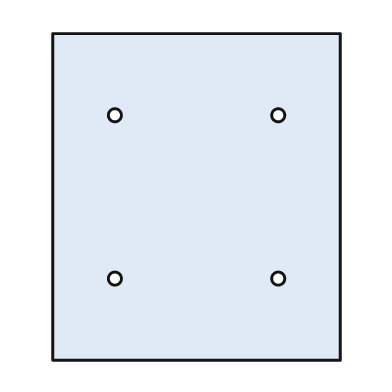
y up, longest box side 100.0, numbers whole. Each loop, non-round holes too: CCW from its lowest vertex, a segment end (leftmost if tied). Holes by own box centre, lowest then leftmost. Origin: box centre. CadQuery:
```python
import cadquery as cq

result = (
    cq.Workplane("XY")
    .moveTo(-44.0, -50.0)
    .lineTo(44.0, -50.0)
    .lineTo(44.0, 50.0)
    .lineTo(-44.0, 50.0)
    .close()
    .moveTo(-25.0, -25.0)
    .circle(2.0)
    .moveTo(25.0, -25.0)
    .circle(2.0)
    .moveTo(-25.0, 25.0)
    .circle(2.0)
    .moveTo(25.0, 25.0)
    .circle(2.0)
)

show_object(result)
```